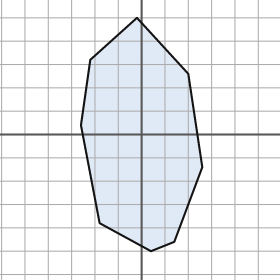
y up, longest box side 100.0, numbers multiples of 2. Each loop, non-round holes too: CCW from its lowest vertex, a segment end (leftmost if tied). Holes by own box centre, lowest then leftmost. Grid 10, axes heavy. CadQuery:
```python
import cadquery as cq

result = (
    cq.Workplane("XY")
    .moveTo(4.0, -50.0)
    .lineTo(14.0, -46.0)
    .lineTo(26.0, -14.0)
    .lineTo(20.0, 26.0)
    .lineTo(-2.0, 50.0)
    .lineTo(-22.0, 32.0)
    .lineTo(-26.0, 4.0)
    .lineTo(-18.0, -38.0)
    .close()
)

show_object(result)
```